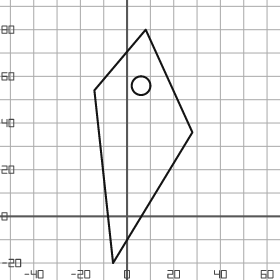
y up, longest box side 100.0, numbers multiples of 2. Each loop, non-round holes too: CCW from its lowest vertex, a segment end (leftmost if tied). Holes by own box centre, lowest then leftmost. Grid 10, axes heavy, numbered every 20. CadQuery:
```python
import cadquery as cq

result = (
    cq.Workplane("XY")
    .moveTo(-6.0, -20.0)
    .lineTo(28.0, 36.0)
    .lineTo(8.0, 80.0)
    .lineTo(-14.0, 54.0)
    .close()
    .moveTo(6.0, 56.0)
    .circle(4.0)
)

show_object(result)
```